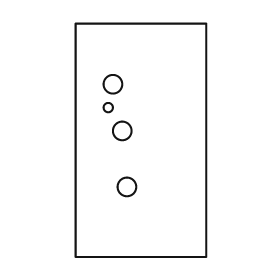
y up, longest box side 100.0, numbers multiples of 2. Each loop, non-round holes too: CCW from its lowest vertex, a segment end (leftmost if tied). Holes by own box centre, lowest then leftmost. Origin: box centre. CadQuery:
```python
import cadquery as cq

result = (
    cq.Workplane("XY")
    .moveTo(-28.0, -50.0)
    .lineTo(28.0, -50.0)
    .lineTo(28.0, 50.0)
    .lineTo(-28.0, 50.0)
    .close()
    .moveTo(-6.0, -20.0)
    .circle(4.0)
    .moveTo(-8.0, 4.0)
    .circle(4.0)
    .moveTo(-14.0, 14.0)
    .circle(2.0)
    .moveTo(-12.0, 24.0)
    .circle(4.0)
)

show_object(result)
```